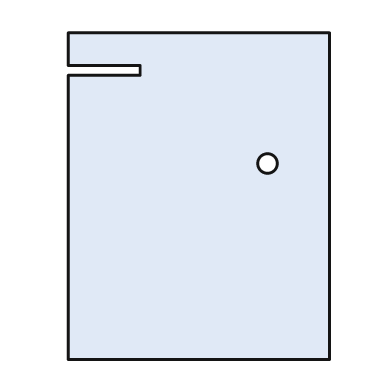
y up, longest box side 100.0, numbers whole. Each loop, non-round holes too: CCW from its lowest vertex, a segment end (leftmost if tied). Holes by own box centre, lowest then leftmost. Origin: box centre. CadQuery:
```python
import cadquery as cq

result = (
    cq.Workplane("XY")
    .moveTo(-40.0, -50.0)
    .lineTo(40.0, -50.0)
    .lineTo(40.0, 50.0)
    .lineTo(-40.0, 50.0)
    .lineTo(-40.0, 40.0)
    .lineTo(-18.0, 40.0)
    .lineTo(-18.0, 37.0)
    .lineTo(-40.0, 37.0)
    .close()
    .moveTo(21.0, 10.0)
    .circle(3.0)
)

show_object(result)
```